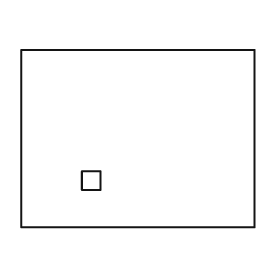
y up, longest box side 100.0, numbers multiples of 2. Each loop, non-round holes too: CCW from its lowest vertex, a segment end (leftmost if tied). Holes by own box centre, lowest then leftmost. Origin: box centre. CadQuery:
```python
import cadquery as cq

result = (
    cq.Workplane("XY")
    .moveTo(-50.0, -38.0)
    .lineTo(50.0, -38.0)
    .lineTo(50.0, 38.0)
    .lineTo(-50.0, 38.0)
    .close()
    .moveTo(-24.0, -22.0)
    .lineTo(-16.0, -22.0)
    .lineTo(-16.0, -14.0)
    .lineTo(-24.0, -14.0)
    .close()
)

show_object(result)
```